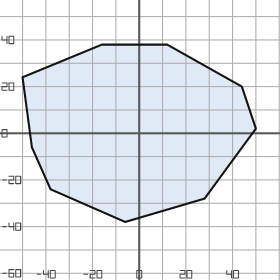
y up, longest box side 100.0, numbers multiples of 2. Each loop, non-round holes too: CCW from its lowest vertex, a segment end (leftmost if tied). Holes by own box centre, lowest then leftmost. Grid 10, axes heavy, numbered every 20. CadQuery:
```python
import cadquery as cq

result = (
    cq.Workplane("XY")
    .moveTo(-6.0, -38.0)
    .lineTo(28.0, -28.0)
    .lineTo(50.0, 2.0)
    .lineTo(44.0, 20.0)
    .lineTo(12.0, 38.0)
    .lineTo(-16.0, 38.0)
    .lineTo(-50.0, 24.0)
    .lineTo(-46.0, -6.0)
    .lineTo(-38.0, -24.0)
    .close()
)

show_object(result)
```